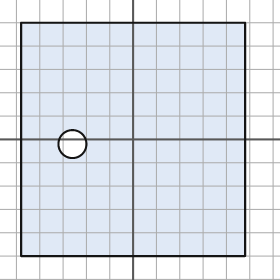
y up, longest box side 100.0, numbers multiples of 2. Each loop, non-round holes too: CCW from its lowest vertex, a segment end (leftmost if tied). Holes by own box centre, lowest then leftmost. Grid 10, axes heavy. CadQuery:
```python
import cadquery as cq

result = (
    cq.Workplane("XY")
    .moveTo(-48.0, -50.0)
    .lineTo(48.0, -50.0)
    .lineTo(48.0, 50.0)
    .lineTo(-48.0, 50.0)
    .close()
    .moveTo(-26.0, -2.0)
    .circle(6.0)
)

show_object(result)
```